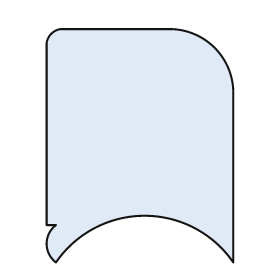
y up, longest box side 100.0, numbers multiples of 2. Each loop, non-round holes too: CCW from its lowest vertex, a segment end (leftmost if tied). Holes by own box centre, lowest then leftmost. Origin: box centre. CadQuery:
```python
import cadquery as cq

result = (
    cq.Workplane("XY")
    .moveTo(-36.0, -50.0)
    .threePointArc((2.0, -30.0), (40.0, -50.0))
    .lineTo(40.0, 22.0)
    .threePointArc((32.0, 42.0), (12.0, 50.0))
    .lineTo(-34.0, 50.0)
    .threePointArc((-38.0, 48.0), (-40.0, 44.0))
    .lineTo(-40.0, -34.0)
    .lineTo(-36.0, -34.0)
    .threePointArc((-40.0, -42.0), (-36.0, -50.0))
    .close()
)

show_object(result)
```